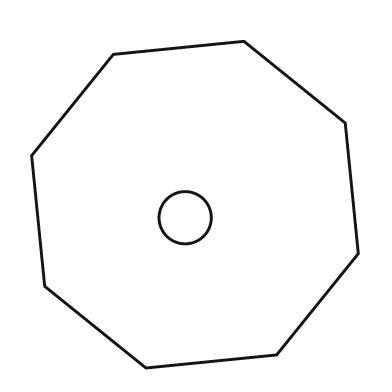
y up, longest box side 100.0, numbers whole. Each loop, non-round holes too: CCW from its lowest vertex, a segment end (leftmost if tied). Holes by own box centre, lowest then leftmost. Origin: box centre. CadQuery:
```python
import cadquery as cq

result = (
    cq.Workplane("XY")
    .moveTo(-15.0, -50.0)
    .lineTo(25.0, -46.0)
    .lineTo(50.0, -15.0)
    .lineTo(46.0, 25.0)
    .lineTo(15.0, 50.0)
    .lineTo(-25.0, 46.0)
    .lineTo(-50.0, 15.0)
    .lineTo(-46.0, -25.0)
    .close()
    .moveTo(-3.0, -4.0)
    .circle(8.0)
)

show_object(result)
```